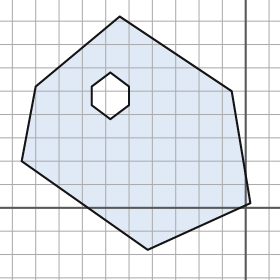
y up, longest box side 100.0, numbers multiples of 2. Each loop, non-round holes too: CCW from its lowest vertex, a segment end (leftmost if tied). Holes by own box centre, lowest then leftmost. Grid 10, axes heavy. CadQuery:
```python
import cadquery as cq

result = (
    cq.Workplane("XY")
    .moveTo(-42.0, -18.0)
    .lineTo(2.0, 2.0)
    .lineTo(-6.0, 50.0)
    .lineTo(-54.0, 82.0)
    .lineTo(-90.0, 52.0)
    .lineTo(-96.0, 20.0)
    .close()
    .moveTo(-58.0, 38.0)
    .lineTo(-50.0, 44.0)
    .lineTo(-50.0, 52.0)
    .lineTo(-58.0, 58.0)
    .lineTo(-66.0, 52.0)
    .lineTo(-66.0, 44.0)
    .close()
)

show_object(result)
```